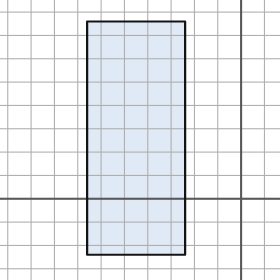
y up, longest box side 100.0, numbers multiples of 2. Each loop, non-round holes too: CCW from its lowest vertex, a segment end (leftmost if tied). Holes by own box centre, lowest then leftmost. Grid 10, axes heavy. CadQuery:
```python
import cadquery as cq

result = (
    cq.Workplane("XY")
    .moveTo(-66.0, -24.0)
    .lineTo(-24.0, -24.0)
    .lineTo(-24.0, 76.0)
    .lineTo(-66.0, 76.0)
    .close()
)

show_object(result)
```